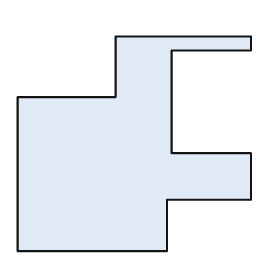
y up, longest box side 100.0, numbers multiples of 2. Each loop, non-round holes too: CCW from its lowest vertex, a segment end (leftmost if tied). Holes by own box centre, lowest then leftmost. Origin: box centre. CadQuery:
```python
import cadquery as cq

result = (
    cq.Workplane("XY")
    .moveTo(-50.0, -46.0)
    .lineTo(14.0, -46.0)
    .lineTo(14.0, -24.0)
    .lineTo(50.0, -24.0)
    .lineTo(50.0, -4.0)
    .lineTo(16.0, -4.0)
    .lineTo(16.0, 40.0)
    .lineTo(50.0, 40.0)
    .lineTo(50.0, 46.0)
    .lineTo(-8.0, 46.0)
    .lineTo(-8.0, 20.0)
    .lineTo(-50.0, 20.0)
    .close()
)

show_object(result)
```